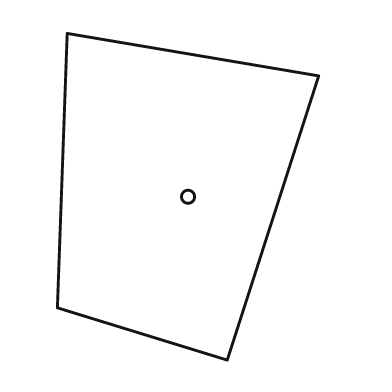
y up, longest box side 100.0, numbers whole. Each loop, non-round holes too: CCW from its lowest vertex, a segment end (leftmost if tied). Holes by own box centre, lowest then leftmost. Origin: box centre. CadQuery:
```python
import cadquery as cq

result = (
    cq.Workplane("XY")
    .moveTo(12.0, -50.0)
    .lineTo(40.0, 37.0)
    .lineTo(-37.0, 50.0)
    .lineTo(-40.0, -34.0)
    .close()
    .moveTo(0.0, 0.0)
    .circle(2.0)
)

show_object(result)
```